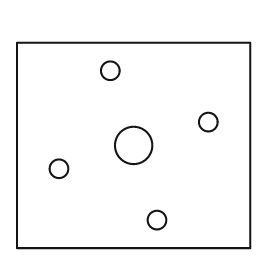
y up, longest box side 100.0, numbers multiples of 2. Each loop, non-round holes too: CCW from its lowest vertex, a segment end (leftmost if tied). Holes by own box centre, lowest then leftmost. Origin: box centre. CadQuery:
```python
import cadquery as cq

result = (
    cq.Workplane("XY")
    .moveTo(-50.0, -44.0)
    .lineTo(50.0, -44.0)
    .lineTo(50.0, 44.0)
    .lineTo(-50.0, 44.0)
    .close()
    .moveTo(10.0, -32.0)
    .circle(4.0)
    .moveTo(-32.0, -10.0)
    .circle(4.0)
    .moveTo(0.0, 0.0)
    .circle(8.0)
    .moveTo(32.0, 10.0)
    .circle(4.0)
    .moveTo(-10.0, 32.0)
    .circle(4.0)
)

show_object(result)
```